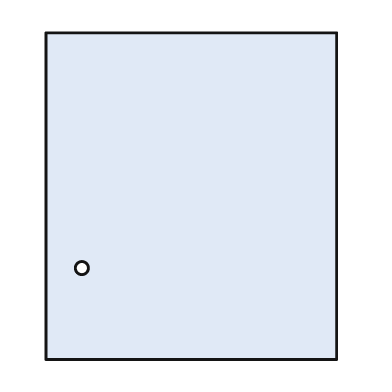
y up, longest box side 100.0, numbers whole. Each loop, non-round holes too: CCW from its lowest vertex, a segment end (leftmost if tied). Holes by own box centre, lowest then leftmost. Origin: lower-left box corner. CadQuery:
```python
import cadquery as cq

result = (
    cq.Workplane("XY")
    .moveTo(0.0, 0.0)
    .lineTo(89.0, 0.0)
    .lineTo(89.0, 100.0)
    .lineTo(0.0, 100.0)
    .close()
    .moveTo(11.0, 28.0)
    .circle(2.0)
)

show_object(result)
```